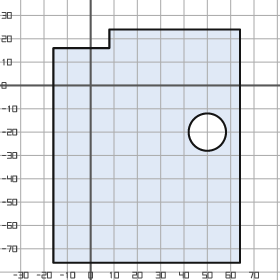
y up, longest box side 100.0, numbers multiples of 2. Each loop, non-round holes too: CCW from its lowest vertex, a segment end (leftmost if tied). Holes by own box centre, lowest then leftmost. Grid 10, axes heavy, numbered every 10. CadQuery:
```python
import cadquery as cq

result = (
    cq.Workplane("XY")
    .moveTo(-16.0, -76.0)
    .lineTo(64.0, -76.0)
    .lineTo(64.0, 24.0)
    .lineTo(8.0, 24.0)
    .lineTo(8.0, 16.0)
    .lineTo(-16.0, 16.0)
    .close()
    .moveTo(50.0, -20.0)
    .circle(8.0)
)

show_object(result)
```